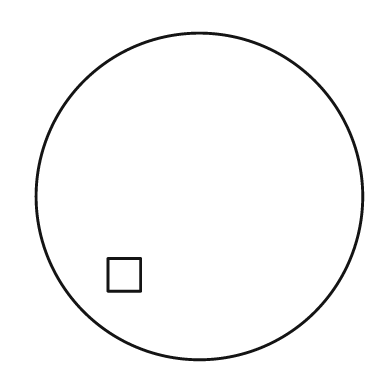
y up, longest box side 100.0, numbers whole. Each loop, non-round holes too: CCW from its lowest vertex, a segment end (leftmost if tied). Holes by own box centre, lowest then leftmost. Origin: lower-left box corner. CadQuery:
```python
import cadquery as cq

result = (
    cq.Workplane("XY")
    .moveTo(50.0, 50.0)
    .circle(50.0)
    .moveTo(22.0, 21.0)
    .lineTo(32.0, 21.0)
    .lineTo(32.0, 31.0)
    .lineTo(22.0, 31.0)
    .close()
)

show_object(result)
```